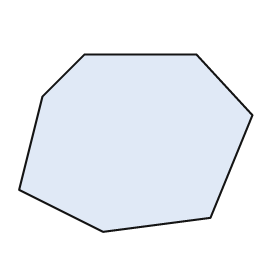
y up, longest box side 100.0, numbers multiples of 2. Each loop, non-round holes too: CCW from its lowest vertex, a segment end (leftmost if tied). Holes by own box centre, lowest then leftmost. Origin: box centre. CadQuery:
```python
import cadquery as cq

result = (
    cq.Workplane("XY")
    .moveTo(-14.0, -38.0)
    .lineTo(32.0, -32.0)
    .lineTo(50.0, 12.0)
    .lineTo(26.0, 38.0)
    .lineTo(-22.0, 38.0)
    .lineTo(-40.0, 20.0)
    .lineTo(-50.0, -20.0)
    .close()
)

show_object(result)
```